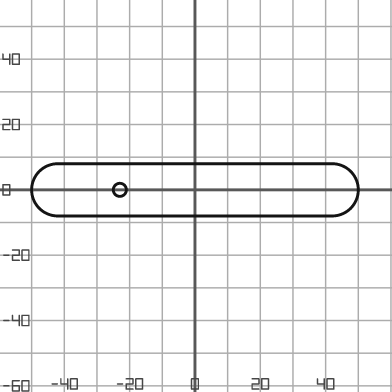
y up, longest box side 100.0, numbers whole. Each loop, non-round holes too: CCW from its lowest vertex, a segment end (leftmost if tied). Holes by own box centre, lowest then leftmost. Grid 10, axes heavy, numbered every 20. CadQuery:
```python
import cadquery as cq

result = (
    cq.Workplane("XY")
    .moveTo(-42.0, -8.0)
    .lineTo(42.0, -8.0)
    .threePointArc((50.0, 0.0), (42.0, 8.0))
    .lineTo(-42.0, 8.0)
    .threePointArc((-50.0, 0.0), (-42.0, -8.0))
    .close()
    .moveTo(-23.0, 0.0)
    .circle(2.0)
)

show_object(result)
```